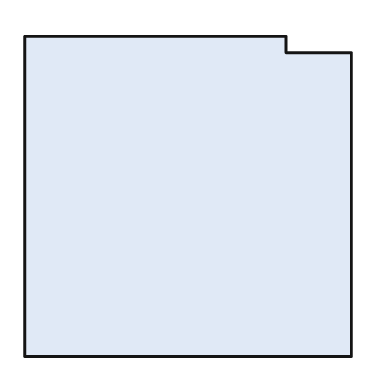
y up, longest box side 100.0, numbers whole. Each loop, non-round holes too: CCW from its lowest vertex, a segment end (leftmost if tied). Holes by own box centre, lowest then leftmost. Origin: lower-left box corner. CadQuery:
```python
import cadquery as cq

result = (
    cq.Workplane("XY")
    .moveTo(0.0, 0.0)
    .lineTo(100.0, 0.0)
    .lineTo(100.0, 93.0)
    .lineTo(80.0, 93.0)
    .lineTo(80.0, 98.0)
    .lineTo(0.0, 98.0)
    .close()
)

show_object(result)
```